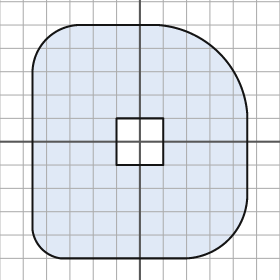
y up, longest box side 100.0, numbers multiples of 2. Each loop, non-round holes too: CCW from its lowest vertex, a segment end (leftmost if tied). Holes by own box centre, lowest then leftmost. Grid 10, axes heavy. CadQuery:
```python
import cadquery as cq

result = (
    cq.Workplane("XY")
    .moveTo(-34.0, -50.0)
    .lineTo(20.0, -50.0)
    .threePointArc((38.0, -42.0), (46.0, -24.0))
    .lineTo(46.0, 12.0)
    .threePointArc((34.0, 38.0), (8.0, 50.0))
    .lineTo(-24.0, 50.0)
    .threePointArc((-40.0, 44.0), (-46.0, 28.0))
    .lineTo(-46.0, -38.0)
    .threePointArc((-42.0, -46.0), (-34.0, -50.0))
    .close()
    .moveTo(-10.0, -10.0)
    .lineTo(10.0, -10.0)
    .lineTo(10.0, 10.0)
    .lineTo(-10.0, 10.0)
    .close()
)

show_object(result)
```